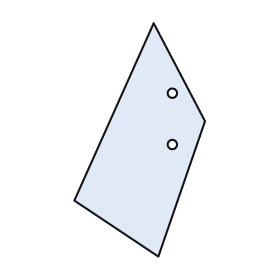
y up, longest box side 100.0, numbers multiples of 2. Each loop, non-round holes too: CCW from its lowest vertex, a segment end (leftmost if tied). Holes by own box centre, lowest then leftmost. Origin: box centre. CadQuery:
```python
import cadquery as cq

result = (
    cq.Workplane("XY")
    .moveTo(8.0, -50.0)
    .lineTo(28.0, 8.0)
    .lineTo(6.0, 50.0)
    .lineTo(-28.0, -26.0)
    .close()
    .moveTo(14.0, -2.0)
    .circle(2.0)
    .moveTo(14.0, 20.0)
    .circle(2.0)
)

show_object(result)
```